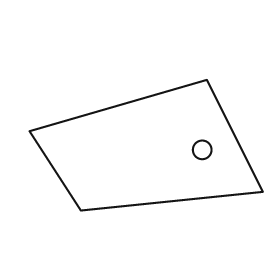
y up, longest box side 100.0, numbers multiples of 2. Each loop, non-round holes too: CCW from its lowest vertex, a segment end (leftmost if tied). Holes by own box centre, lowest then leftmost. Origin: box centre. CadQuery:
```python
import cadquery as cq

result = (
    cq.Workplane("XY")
    .moveTo(-28.0, -28.0)
    .lineTo(50.0, -20.0)
    .lineTo(26.0, 28.0)
    .lineTo(-50.0, 6.0)
    .close()
    .moveTo(24.0, -2.0)
    .circle(4.0)
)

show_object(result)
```